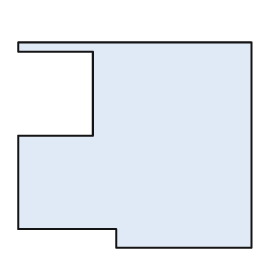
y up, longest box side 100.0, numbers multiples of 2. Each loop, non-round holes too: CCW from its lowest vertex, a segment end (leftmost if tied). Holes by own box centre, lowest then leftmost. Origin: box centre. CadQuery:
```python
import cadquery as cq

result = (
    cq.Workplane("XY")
    .moveTo(-8.0, -44.0)
    .lineTo(50.0, -44.0)
    .lineTo(50.0, 44.0)
    .lineTo(-50.0, 44.0)
    .lineTo(-50.0, 40.0)
    .lineTo(-18.0, 40.0)
    .lineTo(-18.0, 4.0)
    .lineTo(-50.0, 4.0)
    .lineTo(-50.0, -36.0)
    .lineTo(-8.0, -36.0)
    .close()
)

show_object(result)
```